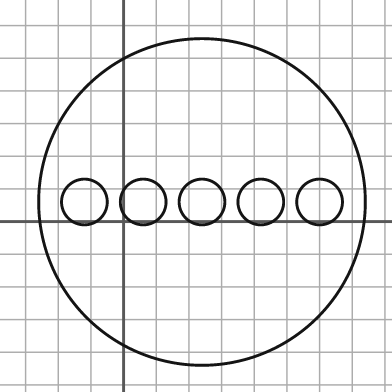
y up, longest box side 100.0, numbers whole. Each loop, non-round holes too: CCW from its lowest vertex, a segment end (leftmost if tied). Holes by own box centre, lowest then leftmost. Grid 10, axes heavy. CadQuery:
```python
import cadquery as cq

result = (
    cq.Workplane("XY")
    .moveTo(24.0, 6.0)
    .circle(50.0)
    .moveTo(-12.0, 6.0)
    .circle(7.0)
    .moveTo(6.0, 6.0)
    .circle(7.0)
    .moveTo(24.0, 6.0)
    .circle(7.0)
    .moveTo(42.0, 6.0)
    .circle(7.0)
    .moveTo(60.0, 6.0)
    .circle(7.0)
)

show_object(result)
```